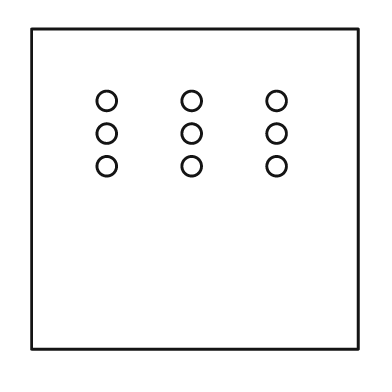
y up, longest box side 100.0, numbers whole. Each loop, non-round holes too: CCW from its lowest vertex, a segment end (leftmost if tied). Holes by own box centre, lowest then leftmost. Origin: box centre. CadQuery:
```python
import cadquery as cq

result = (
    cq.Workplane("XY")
    .moveTo(-50.0, -49.0)
    .lineTo(50.0, -49.0)
    .lineTo(50.0, 49.0)
    .lineTo(-50.0, 49.0)
    .close()
    .moveTo(-27.0, 7.0)
    .circle(3.0)
    .moveTo(-1.0, 7.0)
    .circle(3.0)
    .moveTo(25.0, 7.0)
    .circle(3.0)
    .moveTo(-27.0, 17.0)
    .circle(3.0)
    .moveTo(-1.0, 17.0)
    .circle(3.0)
    .moveTo(25.0, 17.0)
    .circle(3.0)
    .moveTo(-27.0, 27.0)
    .circle(3.0)
    .moveTo(-1.0, 27.0)
    .circle(3.0)
    .moveTo(25.0, 27.0)
    .circle(3.0)
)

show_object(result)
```